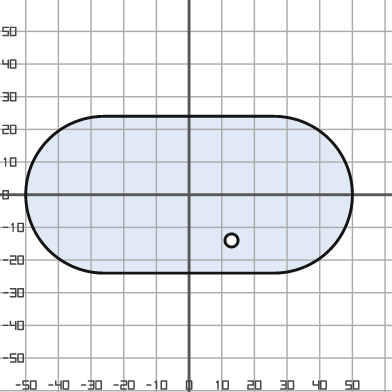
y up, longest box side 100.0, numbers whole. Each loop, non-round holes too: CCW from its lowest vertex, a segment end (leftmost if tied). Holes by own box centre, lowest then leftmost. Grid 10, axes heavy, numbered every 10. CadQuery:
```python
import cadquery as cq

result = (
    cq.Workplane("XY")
    .moveTo(-26.0, -24.0)
    .lineTo(26.0, -24.0)
    .threePointArc((50.0, 0.0), (26.0, 24.0))
    .lineTo(-26.0, 24.0)
    .threePointArc((-50.0, 0.0), (-26.0, -24.0))
    .close()
    .moveTo(13.0, -14.0)
    .circle(2.0)
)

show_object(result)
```